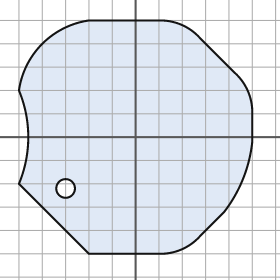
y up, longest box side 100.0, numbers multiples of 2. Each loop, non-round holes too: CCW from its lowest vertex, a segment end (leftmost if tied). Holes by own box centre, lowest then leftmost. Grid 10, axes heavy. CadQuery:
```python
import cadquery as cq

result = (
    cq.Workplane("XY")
    .moveTo(-20.0, -50.0)
    .lineTo(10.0, -50.0)
    .threePointArc((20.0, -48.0), (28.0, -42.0))
    .lineTo(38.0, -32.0)
    .threePointArc((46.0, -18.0), (50.0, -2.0))
    .lineTo(50.0, 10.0)
    .threePointArc((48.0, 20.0), (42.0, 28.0))
    .lineTo(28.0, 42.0)
    .threePointArc((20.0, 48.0), (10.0, 50.0))
    .lineTo(-20.0, 50.0)
    .threePointArc((-40.0, 40.0), (-50.0, 20.0))
    .threePointArc((-46.0, 0.0), (-50.0, -20.0))
    .close()
    .moveTo(-30.0, -22.0)
    .circle(4.0)
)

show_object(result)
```